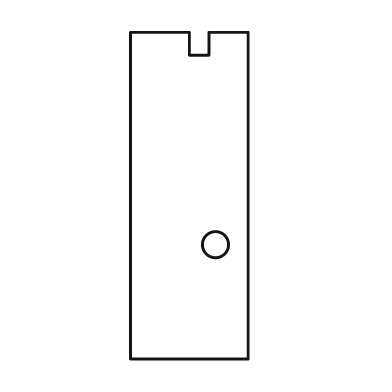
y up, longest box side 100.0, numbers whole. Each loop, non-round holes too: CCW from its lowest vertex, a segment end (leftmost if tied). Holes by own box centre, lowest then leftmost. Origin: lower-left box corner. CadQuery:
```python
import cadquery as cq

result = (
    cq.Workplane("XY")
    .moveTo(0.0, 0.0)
    .lineTo(36.0, 0.0)
    .lineTo(36.0, 100.0)
    .lineTo(24.0, 100.0)
    .lineTo(24.0, 93.0)
    .lineTo(18.0, 93.0)
    .lineTo(18.0, 100.0)
    .lineTo(0.0, 100.0)
    .close()
    .moveTo(26.0, 35.0)
    .circle(4.0)
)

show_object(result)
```